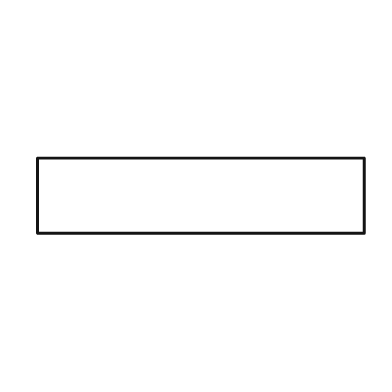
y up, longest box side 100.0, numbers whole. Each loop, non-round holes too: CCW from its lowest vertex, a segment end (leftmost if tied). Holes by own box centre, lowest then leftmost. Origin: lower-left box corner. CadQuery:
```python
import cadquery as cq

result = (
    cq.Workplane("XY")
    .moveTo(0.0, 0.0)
    .lineTo(100.0, 0.0)
    .lineTo(100.0, 23.0)
    .lineTo(0.0, 23.0)
    .close()
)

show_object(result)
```